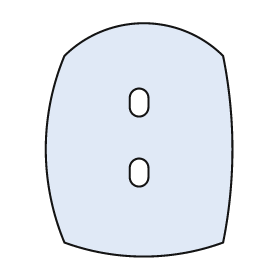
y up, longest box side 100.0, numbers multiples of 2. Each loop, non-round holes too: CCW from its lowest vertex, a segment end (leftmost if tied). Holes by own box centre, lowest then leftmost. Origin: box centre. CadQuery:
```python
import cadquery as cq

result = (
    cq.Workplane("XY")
    .moveTo(-32.0, -44.0)
    .threePointArc((2.0, -50.0), (36.0, -44.0))
    .threePointArc((40.0, -4.0), (36.0, 36.0))
    .threePointArc((2.0, 50.0), (-32.0, 36.0))
    .threePointArc((-40.0, -4.0), (-32.0, -44.0))
    .close()
    .moveTo(-4.0, -16.0)
    .threePointArc((0.0, -20.0), (4.0, -16.0))
    .lineTo(4.0, -12.0)
    .threePointArc((0.0, -8.0), (-4.0, -12.0))
    .close()
    .moveTo(-4.0, 14.0)
    .threePointArc((0.0, 10.0), (4.0, 14.0))
    .lineTo(4.0, 18.0)
    .threePointArc((0.0, 22.0), (-4.0, 18.0))
    .close()
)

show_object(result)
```